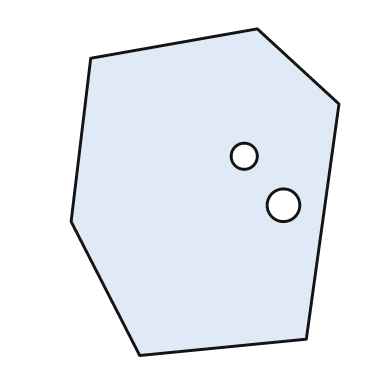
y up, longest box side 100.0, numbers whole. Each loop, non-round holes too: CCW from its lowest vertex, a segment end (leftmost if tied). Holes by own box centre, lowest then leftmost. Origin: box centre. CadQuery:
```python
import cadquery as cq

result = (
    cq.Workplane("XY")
    .moveTo(-20.0, -50.0)
    .lineTo(31.0, -45.0)
    .lineTo(41.0, 27.0)
    .lineTo(16.0, 50.0)
    .lineTo(-35.0, 41.0)
    .lineTo(-41.0, -9.0)
    .close()
    .moveTo(24.0, -4.0)
    .circle(5.0)
    .moveTo(12.0, 11.0)
    .circle(4.0)
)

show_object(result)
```